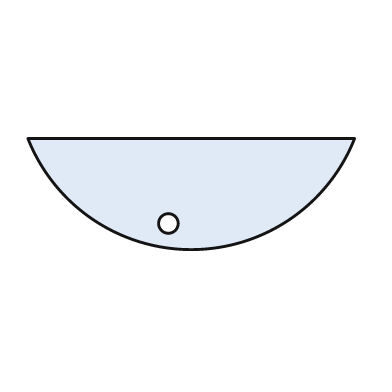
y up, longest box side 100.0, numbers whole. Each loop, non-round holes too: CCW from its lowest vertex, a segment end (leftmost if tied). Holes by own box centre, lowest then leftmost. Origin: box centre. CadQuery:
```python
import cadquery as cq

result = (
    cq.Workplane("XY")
    .moveTo(-50.0, 17.0)
    .threePointArc((0.0, -17.0), (50.0, 17.0))
    .close()
    .moveTo(-7.0, -9.0)
    .circle(3.0)
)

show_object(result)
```